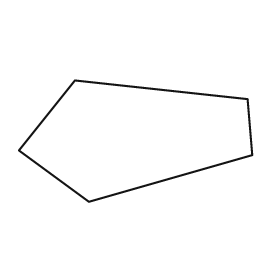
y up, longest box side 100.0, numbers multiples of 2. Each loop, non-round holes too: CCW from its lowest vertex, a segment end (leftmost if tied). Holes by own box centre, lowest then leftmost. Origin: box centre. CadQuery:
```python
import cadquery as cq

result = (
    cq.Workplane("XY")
    .moveTo(-20.0, -26.0)
    .lineTo(50.0, -6.0)
    .lineTo(48.0, 18.0)
    .lineTo(-26.0, 26.0)
    .lineTo(-50.0, -4.0)
    .close()
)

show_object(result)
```